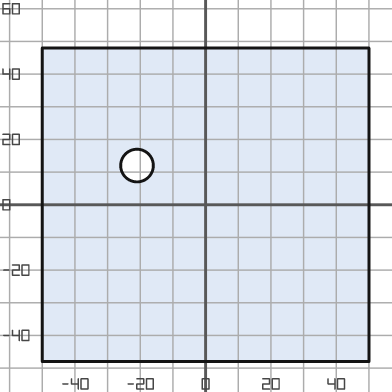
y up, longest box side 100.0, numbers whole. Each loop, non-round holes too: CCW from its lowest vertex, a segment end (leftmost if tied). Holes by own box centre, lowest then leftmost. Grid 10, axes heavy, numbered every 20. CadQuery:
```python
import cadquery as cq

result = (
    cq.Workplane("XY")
    .moveTo(-50.0, -48.0)
    .lineTo(50.0, -48.0)
    .lineTo(50.0, 48.0)
    .lineTo(-50.0, 48.0)
    .close()
    .moveTo(-21.0, 12.0)
    .circle(5.0)
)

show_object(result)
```